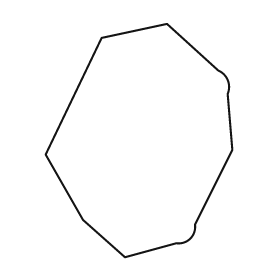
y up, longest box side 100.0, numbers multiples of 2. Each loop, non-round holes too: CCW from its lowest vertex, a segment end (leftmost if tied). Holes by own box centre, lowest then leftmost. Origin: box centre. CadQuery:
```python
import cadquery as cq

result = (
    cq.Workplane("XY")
    .moveTo(-6.0, -50.0)
    .lineTo(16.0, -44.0)
    .threePointArc((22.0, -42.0), (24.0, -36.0))
    .lineTo(40.0, -4.0)
    .lineTo(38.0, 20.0)
    .threePointArc((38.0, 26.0), (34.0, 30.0))
    .lineTo(12.0, 50.0)
    .lineTo(-16.0, 44.0)
    .lineTo(-40.0, -6.0)
    .lineTo(-24.0, -34.0)
    .close()
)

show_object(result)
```